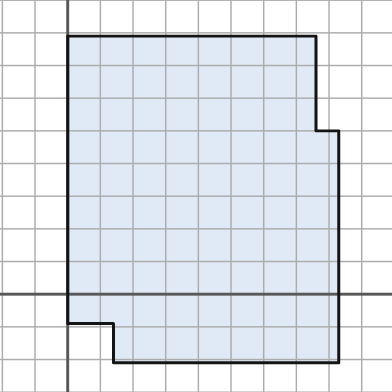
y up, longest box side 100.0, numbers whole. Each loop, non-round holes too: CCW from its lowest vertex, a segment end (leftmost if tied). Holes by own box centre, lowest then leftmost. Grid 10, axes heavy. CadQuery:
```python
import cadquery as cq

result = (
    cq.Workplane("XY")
    .moveTo(14.0, -21.0)
    .lineTo(83.0, -21.0)
    .lineTo(83.0, 50.0)
    .lineTo(76.0, 50.0)
    .lineTo(76.0, 79.0)
    .lineTo(0.0, 79.0)
    .lineTo(0.0, -9.0)
    .lineTo(14.0, -9.0)
    .close()
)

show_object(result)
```